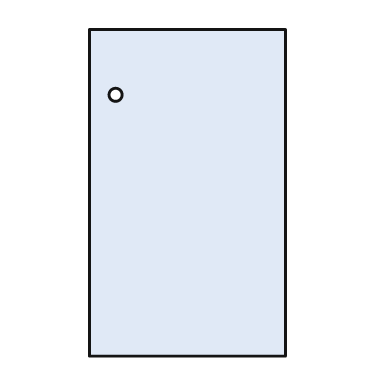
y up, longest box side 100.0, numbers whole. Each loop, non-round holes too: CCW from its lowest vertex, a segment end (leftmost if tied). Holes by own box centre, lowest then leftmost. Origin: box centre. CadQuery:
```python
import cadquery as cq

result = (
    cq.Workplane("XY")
    .moveTo(-30.0, -50.0)
    .lineTo(30.0, -50.0)
    .lineTo(30.0, 50.0)
    .lineTo(-30.0, 50.0)
    .close()
    .moveTo(-22.0, 30.0)
    .circle(2.0)
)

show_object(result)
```